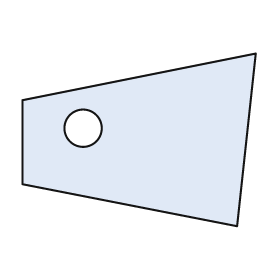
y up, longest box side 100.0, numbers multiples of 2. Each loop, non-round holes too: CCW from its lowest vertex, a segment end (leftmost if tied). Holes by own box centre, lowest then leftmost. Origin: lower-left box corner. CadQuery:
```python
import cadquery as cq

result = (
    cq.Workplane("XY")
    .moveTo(92.0, 0.0)
    .lineTo(100.0, 74.0)
    .lineTo(0.0, 54.0)
    .lineTo(0.0, 18.0)
    .close()
    .moveTo(26.0, 42.0)
    .circle(8.0)
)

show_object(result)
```